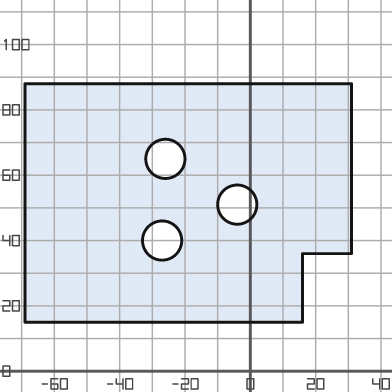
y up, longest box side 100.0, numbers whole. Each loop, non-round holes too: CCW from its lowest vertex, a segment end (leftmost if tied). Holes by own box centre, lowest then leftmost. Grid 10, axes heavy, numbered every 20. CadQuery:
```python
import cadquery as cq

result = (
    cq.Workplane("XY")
    .moveTo(-69.0, 15.0)
    .lineTo(16.0, 15.0)
    .lineTo(16.0, 36.0)
    .lineTo(31.0, 36.0)
    .lineTo(31.0, 88.0)
    .lineTo(-69.0, 88.0)
    .close()
    .moveTo(-27.0, 40.0)
    .circle(6.0)
    .moveTo(-4.0, 51.0)
    .circle(6.0)
    .moveTo(-26.0, 65.0)
    .circle(6.0)
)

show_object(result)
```